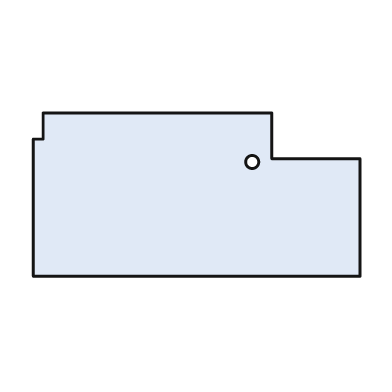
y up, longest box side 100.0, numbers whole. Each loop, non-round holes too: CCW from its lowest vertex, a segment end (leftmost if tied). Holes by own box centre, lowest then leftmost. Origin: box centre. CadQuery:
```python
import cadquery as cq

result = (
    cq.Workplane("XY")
    .moveTo(-50.0, -25.0)
    .lineTo(50.0, -25.0)
    .lineTo(50.0, 11.0)
    .lineTo(23.0, 11.0)
    .lineTo(23.0, 25.0)
    .lineTo(-47.0, 25.0)
    .lineTo(-47.0, 17.0)
    .lineTo(-50.0, 17.0)
    .close()
    .moveTo(17.0, 10.0)
    .circle(2.0)
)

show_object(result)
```